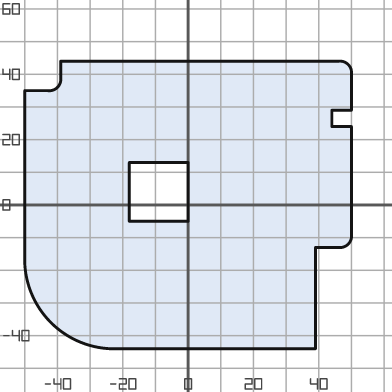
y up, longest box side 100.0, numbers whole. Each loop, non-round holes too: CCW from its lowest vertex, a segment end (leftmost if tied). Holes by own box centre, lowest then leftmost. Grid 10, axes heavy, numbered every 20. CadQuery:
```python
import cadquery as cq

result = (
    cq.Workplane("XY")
    .moveTo(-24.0, -44.0)
    .lineTo(39.0, -44.0)
    .lineTo(39.0, -13.0)
    .lineTo(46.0, -13.0)
    .threePointArc((49.0, -12.0), (50.0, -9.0))
    .lineTo(50.0, 24.0)
    .lineTo(44.0, 24.0)
    .lineTo(44.0, 29.0)
    .lineTo(50.0, 29.0)
    .lineTo(50.0, 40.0)
    .threePointArc((49.0, 43.0), (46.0, 44.0))
    .lineTo(-39.0, 44.0)
    .lineTo(-39.0, 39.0)
    .threePointArc((-40.0, 36.0), (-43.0, 35.0))
    .lineTo(-50.0, 35.0)
    .lineTo(-50.0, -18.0)
    .threePointArc((-42.0, -36.0), (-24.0, -44.0))
    .close()
    .moveTo(-18.0, -5.0)
    .lineTo(0.0, -5.0)
    .lineTo(0.0, 13.0)
    .lineTo(-18.0, 13.0)
    .close()
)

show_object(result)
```